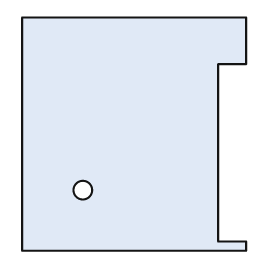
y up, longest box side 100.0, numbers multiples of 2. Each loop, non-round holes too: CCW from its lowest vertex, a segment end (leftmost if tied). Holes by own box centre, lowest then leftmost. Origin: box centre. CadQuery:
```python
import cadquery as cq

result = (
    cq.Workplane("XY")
    .moveTo(-48.0, -50.0)
    .lineTo(48.0, -50.0)
    .lineTo(48.0, -46.0)
    .lineTo(36.0, -46.0)
    .lineTo(36.0, 30.0)
    .lineTo(48.0, 30.0)
    .lineTo(48.0, 50.0)
    .lineTo(-48.0, 50.0)
    .close()
    .moveTo(-22.0, -24.0)
    .circle(4.0)
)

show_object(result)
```